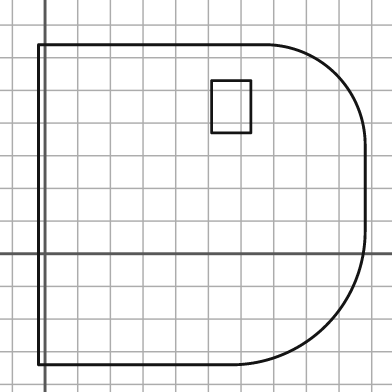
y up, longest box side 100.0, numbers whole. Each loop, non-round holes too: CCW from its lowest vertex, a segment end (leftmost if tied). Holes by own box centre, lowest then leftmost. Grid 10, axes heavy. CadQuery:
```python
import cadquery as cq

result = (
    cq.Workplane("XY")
    .moveTo(-2.0, -34.0)
    .lineTo(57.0, -34.0)
    .threePointArc((86.0, -22.0), (98.0, 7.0))
    .lineTo(98.0, 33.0)
    .threePointArc((89.0, 55.0), (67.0, 64.0))
    .lineTo(-2.0, 64.0)
    .close()
    .moveTo(51.0, 37.0)
    .lineTo(63.0, 37.0)
    .lineTo(63.0, 53.0)
    .lineTo(51.0, 53.0)
    .close()
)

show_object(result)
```